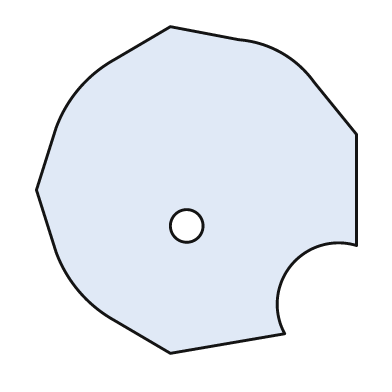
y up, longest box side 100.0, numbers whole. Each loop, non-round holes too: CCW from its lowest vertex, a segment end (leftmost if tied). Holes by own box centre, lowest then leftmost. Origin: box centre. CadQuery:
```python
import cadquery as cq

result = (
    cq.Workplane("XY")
    .moveTo(-8.0, -50.0)
    .lineTo(27.0, -44.0)
    .threePointArc((29.0, -23.0), (49.0, -17.0))
    .lineTo(49.0, 17.0)
    .lineTo(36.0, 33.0)
    .threePointArc((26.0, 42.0), (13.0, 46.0))
    .lineTo(-8.0, 50.0)
    .lineTo(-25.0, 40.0)
    .threePointArc((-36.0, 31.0), (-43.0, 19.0))
    .lineTo(-49.0, 0.0)
    .lineTo(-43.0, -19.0)
    .threePointArc((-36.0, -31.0), (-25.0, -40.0))
    .close()
    .moveTo(-3.0, -11.0)
    .circle(5.0)
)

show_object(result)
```